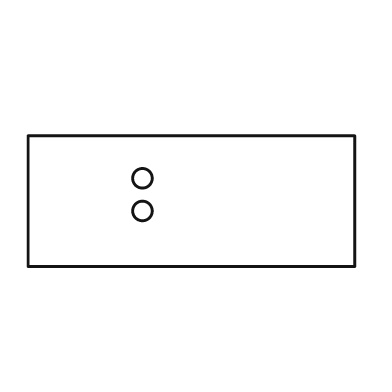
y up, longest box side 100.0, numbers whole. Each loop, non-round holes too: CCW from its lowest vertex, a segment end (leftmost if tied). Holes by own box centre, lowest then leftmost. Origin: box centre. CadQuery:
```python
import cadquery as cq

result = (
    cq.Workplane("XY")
    .moveTo(-50.0, -20.0)
    .lineTo(50.0, -20.0)
    .lineTo(50.0, 20.0)
    .lineTo(-50.0, 20.0)
    .close()
    .moveTo(-15.0, -3.0)
    .circle(3.0)
    .moveTo(-15.0, 7.0)
    .circle(3.0)
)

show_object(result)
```